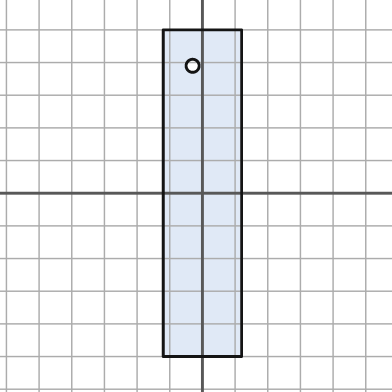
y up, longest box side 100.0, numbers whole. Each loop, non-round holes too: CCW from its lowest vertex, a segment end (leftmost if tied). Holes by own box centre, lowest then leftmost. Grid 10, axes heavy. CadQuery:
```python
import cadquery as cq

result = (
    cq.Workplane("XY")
    .moveTo(-12.0, -50.0)
    .lineTo(12.0, -50.0)
    .lineTo(12.0, 50.0)
    .lineTo(-12.0, 50.0)
    .close()
    .moveTo(-3.0, 39.0)
    .circle(2.0)
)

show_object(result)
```